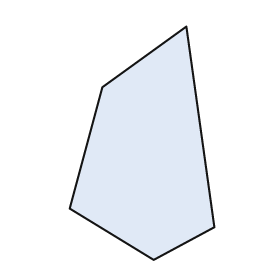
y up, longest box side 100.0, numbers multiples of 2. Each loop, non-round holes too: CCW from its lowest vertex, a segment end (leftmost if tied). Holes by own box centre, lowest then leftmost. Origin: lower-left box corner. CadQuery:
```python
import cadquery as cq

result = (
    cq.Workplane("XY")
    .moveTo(36.0, 0.0)
    .lineTo(62.0, 14.0)
    .lineTo(50.0, 100.0)
    .lineTo(14.0, 74.0)
    .lineTo(0.0, 22.0)
    .close()
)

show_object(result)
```